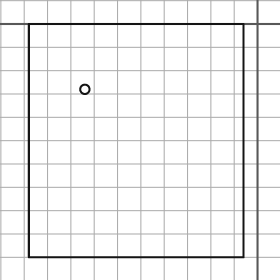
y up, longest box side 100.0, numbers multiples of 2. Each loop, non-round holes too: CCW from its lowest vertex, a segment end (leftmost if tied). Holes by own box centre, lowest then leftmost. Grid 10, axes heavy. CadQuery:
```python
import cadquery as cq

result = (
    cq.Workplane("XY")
    .moveTo(-98.0, -100.0)
    .lineTo(-6.0, -100.0)
    .lineTo(-6.0, 0.0)
    .lineTo(-98.0, 0.0)
    .close()
    .moveTo(-74.0, -28.0)
    .circle(2.0)
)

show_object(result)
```